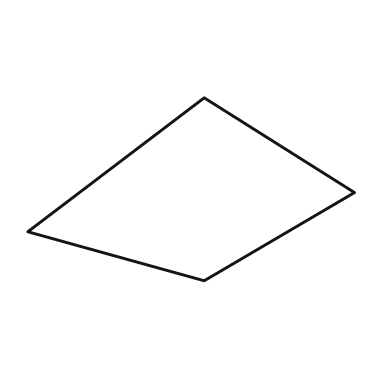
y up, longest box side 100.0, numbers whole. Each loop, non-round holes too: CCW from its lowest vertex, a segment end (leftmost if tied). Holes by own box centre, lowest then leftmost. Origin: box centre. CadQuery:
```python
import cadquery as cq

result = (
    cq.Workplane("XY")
    .moveTo(4.0, -28.0)
    .lineTo(50.0, -1.0)
    .lineTo(4.0, 28.0)
    .lineTo(-50.0, -13.0)
    .close()
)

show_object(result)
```